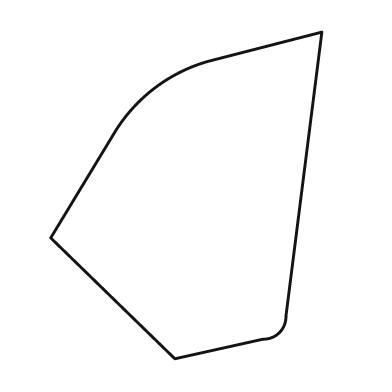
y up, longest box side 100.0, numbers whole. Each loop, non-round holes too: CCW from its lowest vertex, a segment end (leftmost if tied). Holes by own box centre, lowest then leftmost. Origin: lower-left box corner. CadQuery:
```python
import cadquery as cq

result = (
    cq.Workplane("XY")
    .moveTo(38.0, 0.0)
    .lineTo(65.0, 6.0)
    .threePointArc((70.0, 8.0), (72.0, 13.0))
    .lineTo(83.0, 100.0)
    .lineTo(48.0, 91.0)
    .threePointArc((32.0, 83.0), (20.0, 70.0))
    .lineTo(0.0, 37.0)
    .close()
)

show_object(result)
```